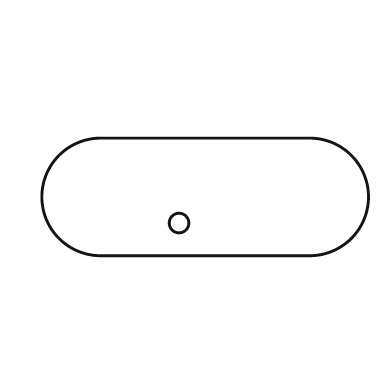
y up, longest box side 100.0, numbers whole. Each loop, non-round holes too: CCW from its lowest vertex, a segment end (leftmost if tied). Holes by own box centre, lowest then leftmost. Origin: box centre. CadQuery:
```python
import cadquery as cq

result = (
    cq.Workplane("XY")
    .moveTo(-32.0, -18.0)
    .lineTo(32.0, -18.0)
    .threePointArc((50.0, 0.0), (32.0, 18.0))
    .lineTo(-32.0, 18.0)
    .threePointArc((-50.0, 0.0), (-32.0, -18.0))
    .close()
    .moveTo(-8.0, -8.0)
    .circle(3.0)
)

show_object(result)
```